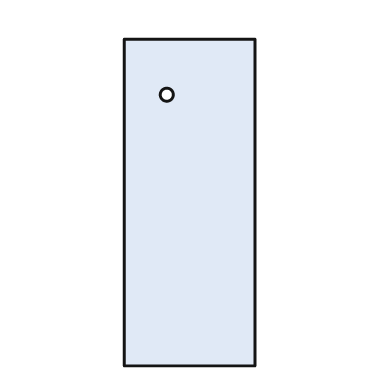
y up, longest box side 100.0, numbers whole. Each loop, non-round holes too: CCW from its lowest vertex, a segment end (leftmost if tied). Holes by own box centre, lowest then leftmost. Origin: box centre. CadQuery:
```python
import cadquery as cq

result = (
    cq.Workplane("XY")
    .moveTo(-20.0, -50.0)
    .lineTo(20.0, -50.0)
    .lineTo(20.0, 50.0)
    .lineTo(-20.0, 50.0)
    .close()
    .moveTo(-7.0, 33.0)
    .circle(2.0)
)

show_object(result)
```